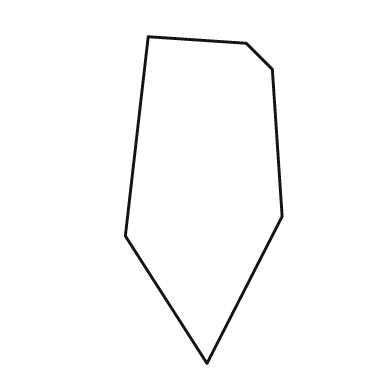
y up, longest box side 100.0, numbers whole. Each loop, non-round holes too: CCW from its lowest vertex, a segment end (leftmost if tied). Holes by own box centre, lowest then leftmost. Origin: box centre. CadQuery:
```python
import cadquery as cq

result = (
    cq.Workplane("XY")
    .moveTo(1.0, -50.0)
    .lineTo(24.0, -5.0)
    .lineTo(21.0, 40.0)
    .lineTo(13.0, 48.0)
    .lineTo(-17.0, 50.0)
    .lineTo(-24.0, -11.0)
    .close()
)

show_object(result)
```